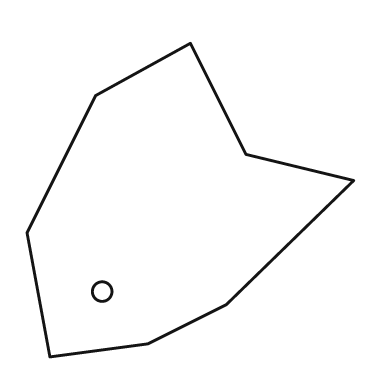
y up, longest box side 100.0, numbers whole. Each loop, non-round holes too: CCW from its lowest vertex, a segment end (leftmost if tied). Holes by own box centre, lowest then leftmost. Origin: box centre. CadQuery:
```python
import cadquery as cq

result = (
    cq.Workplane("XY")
    .moveTo(-43.0, -48.0)
    .lineTo(-13.0, -44.0)
    .lineTo(11.0, -32.0)
    .lineTo(50.0, 6.0)
    .lineTo(17.0, 14.0)
    .lineTo(0.0, 48.0)
    .lineTo(-29.0, 32.0)
    .lineTo(-50.0, -10.0)
    .close()
    .moveTo(-27.0, -28.0)
    .circle(3.0)
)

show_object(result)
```